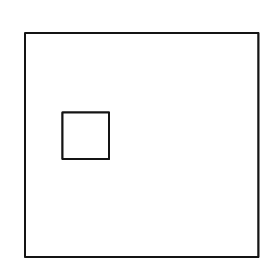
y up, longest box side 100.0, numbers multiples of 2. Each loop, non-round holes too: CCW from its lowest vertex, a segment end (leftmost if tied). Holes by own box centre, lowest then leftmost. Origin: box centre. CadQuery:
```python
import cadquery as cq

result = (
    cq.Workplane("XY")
    .moveTo(-50.0, -48.0)
    .lineTo(50.0, -48.0)
    .lineTo(50.0, 48.0)
    .lineTo(-50.0, 48.0)
    .close()
    .moveTo(-34.0, -6.0)
    .lineTo(-14.0, -6.0)
    .lineTo(-14.0, 14.0)
    .lineTo(-34.0, 14.0)
    .close()
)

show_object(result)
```